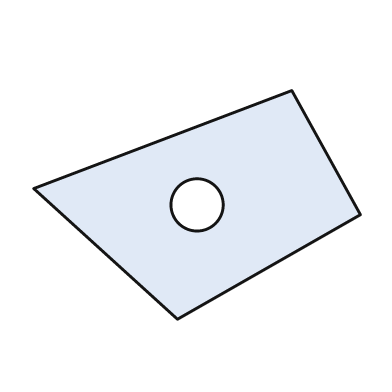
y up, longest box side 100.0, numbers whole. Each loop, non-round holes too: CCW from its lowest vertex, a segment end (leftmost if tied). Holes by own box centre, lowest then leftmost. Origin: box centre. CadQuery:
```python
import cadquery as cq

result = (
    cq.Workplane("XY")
    .moveTo(-6.0, -35.0)
    .lineTo(50.0, -3.0)
    .lineTo(29.0, 35.0)
    .lineTo(-50.0, 5.0)
    .close()
    .moveTo(0.0, 0.0)
    .circle(8.0)
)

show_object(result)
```